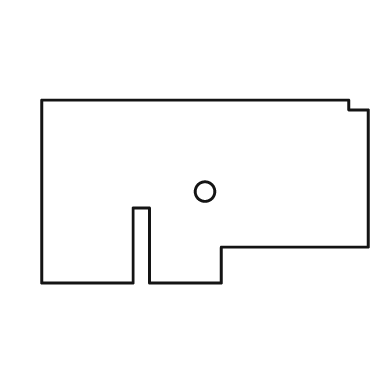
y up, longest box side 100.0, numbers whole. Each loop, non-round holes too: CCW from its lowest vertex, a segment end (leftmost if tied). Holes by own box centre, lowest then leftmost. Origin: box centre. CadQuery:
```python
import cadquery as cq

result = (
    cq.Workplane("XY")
    .moveTo(-50.0, -28.0)
    .lineTo(-22.0, -28.0)
    .lineTo(-22.0, -5.0)
    .lineTo(-17.0, -5.0)
    .lineTo(-17.0, -28.0)
    .lineTo(5.0, -28.0)
    .lineTo(5.0, -17.0)
    .lineTo(50.0, -17.0)
    .lineTo(50.0, 25.0)
    .lineTo(44.0, 25.0)
    .lineTo(44.0, 28.0)
    .lineTo(-50.0, 28.0)
    .close()
    .moveTo(0.0, 0.0)
    .circle(3.0)
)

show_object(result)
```